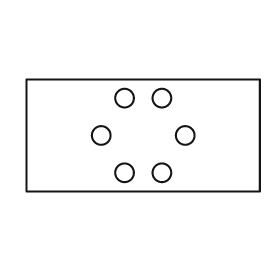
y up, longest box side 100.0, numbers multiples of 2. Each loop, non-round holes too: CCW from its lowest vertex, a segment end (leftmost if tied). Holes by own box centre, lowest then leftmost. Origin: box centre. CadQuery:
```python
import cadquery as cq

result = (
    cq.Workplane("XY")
    .moveTo(-50.0, -24.0)
    .lineTo(50.0, -24.0)
    .lineTo(50.0, 24.0)
    .lineTo(-50.0, 24.0)
    .close()
    .moveTo(-8.0, -16.0)
    .circle(4.0)
    .moveTo(8.0, -16.0)
    .circle(4.0)
    .moveTo(-18.0, 0.0)
    .circle(4.0)
    .moveTo(18.0, 0.0)
    .circle(4.0)
    .moveTo(-8.0, 16.0)
    .circle(4.0)
    .moveTo(8.0, 16.0)
    .circle(4.0)
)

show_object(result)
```